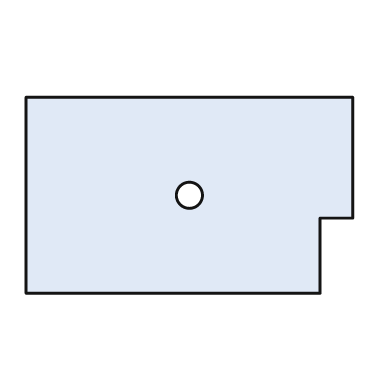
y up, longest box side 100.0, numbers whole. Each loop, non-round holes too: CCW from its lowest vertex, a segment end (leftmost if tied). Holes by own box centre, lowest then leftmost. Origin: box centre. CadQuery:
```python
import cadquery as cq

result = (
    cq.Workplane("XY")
    .moveTo(-50.0, -30.0)
    .lineTo(40.0, -30.0)
    .lineTo(40.0, -7.0)
    .lineTo(50.0, -7.0)
    .lineTo(50.0, 30.0)
    .lineTo(-50.0, 30.0)
    .close()
    .moveTo(0.0, 0.0)
    .circle(4.0)
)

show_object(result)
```